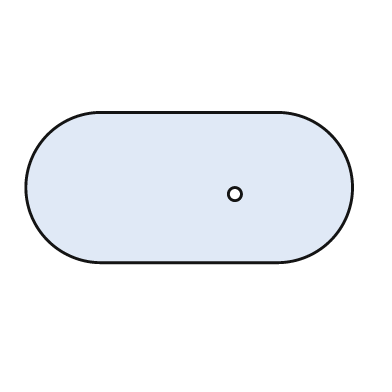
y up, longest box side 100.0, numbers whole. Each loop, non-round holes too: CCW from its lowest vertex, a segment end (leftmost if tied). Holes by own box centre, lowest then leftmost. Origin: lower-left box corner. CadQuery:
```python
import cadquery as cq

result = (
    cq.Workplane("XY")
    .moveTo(23.0, 0.0)
    .lineTo(77.0, 0.0)
    .threePointArc((100.0, 23.0), (77.0, 46.0))
    .lineTo(23.0, 46.0)
    .threePointArc((0.0, 23.0), (23.0, 0.0))
    .close()
    .moveTo(64.0, 21.0)
    .circle(2.0)
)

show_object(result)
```